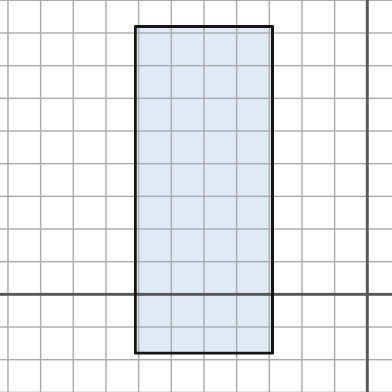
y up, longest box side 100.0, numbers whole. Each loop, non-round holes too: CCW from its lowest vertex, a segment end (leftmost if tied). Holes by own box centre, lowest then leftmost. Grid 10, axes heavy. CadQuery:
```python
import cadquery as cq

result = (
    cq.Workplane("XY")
    .moveTo(-71.0, -18.0)
    .lineTo(-29.0, -18.0)
    .lineTo(-29.0, 82.0)
    .lineTo(-71.0, 82.0)
    .close()
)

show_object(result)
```